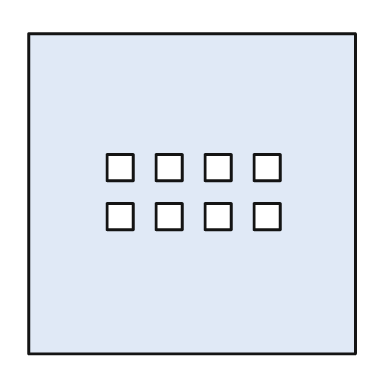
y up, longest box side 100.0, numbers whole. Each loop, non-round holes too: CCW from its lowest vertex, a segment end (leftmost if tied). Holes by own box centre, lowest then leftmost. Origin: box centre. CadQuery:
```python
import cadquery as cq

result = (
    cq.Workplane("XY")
    .moveTo(-50.0, -49.0)
    .lineTo(50.0, -49.0)
    .lineTo(50.0, 49.0)
    .lineTo(-50.0, 49.0)
    .close()
    .moveTo(-26.0, -11.0)
    .lineTo(-18.0, -11.0)
    .lineTo(-18.0, -3.0)
    .lineTo(-26.0, -3.0)
    .close()
    .moveTo(-11.0, -11.0)
    .lineTo(-3.0, -11.0)
    .lineTo(-3.0, -3.0)
    .lineTo(-11.0, -3.0)
    .close()
    .moveTo(4.0, -11.0)
    .lineTo(12.0, -11.0)
    .lineTo(12.0, -3.0)
    .lineTo(4.0, -3.0)
    .close()
    .moveTo(19.0, -11.0)
    .lineTo(27.0, -11.0)
    .lineTo(27.0, -3.0)
    .lineTo(19.0, -3.0)
    .close()
    .moveTo(-26.0, 4.0)
    .lineTo(-18.0, 4.0)
    .lineTo(-18.0, 12.0)
    .lineTo(-26.0, 12.0)
    .close()
    .moveTo(-11.0, 4.0)
    .lineTo(-3.0, 4.0)
    .lineTo(-3.0, 12.0)
    .lineTo(-11.0, 12.0)
    .close()
    .moveTo(4.0, 4.0)
    .lineTo(12.0, 4.0)
    .lineTo(12.0, 12.0)
    .lineTo(4.0, 12.0)
    .close()
    .moveTo(19.0, 4.0)
    .lineTo(27.0, 4.0)
    .lineTo(27.0, 12.0)
    .lineTo(19.0, 12.0)
    .close()
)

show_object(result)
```